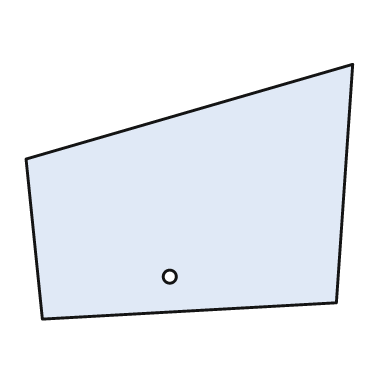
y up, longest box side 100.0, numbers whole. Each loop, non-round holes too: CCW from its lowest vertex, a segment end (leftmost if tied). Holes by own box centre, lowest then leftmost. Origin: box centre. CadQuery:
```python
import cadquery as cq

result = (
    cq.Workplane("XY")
    .moveTo(-45.0, -39.0)
    .lineTo(45.0, -34.0)
    .lineTo(50.0, 39.0)
    .lineTo(-50.0, 10.0)
    .close()
    .moveTo(-6.0, -26.0)
    .circle(2.0)
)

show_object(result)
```